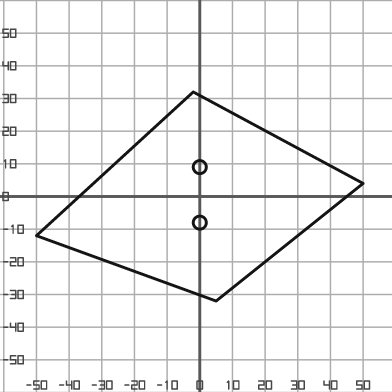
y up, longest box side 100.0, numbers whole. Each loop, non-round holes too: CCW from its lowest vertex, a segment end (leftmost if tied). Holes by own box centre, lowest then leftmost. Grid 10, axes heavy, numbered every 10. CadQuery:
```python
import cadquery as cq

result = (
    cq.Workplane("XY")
    .moveTo(5.0, -32.0)
    .lineTo(50.0, 4.0)
    .lineTo(-2.0, 32.0)
    .lineTo(-50.0, -12.0)
    .close()
    .moveTo(0.0, -8.0)
    .circle(2.0)
    .moveTo(0.0, 9.0)
    .circle(2.0)
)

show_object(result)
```